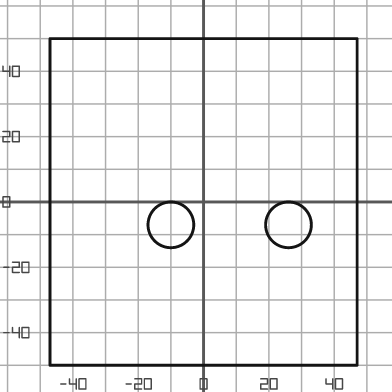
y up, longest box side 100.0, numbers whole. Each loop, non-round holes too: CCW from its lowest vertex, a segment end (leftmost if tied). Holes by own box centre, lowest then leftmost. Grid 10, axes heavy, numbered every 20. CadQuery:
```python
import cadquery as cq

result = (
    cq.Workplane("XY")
    .moveTo(-47.0, -50.0)
    .lineTo(47.0, -50.0)
    .lineTo(47.0, 50.0)
    .lineTo(-47.0, 50.0)
    .close()
    .moveTo(-10.0, -7.0)
    .circle(7.0)
    .moveTo(26.0, -7.0)
    .circle(7.0)
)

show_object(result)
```